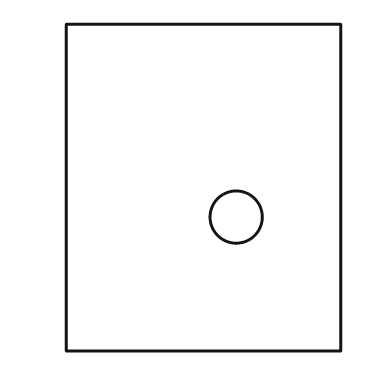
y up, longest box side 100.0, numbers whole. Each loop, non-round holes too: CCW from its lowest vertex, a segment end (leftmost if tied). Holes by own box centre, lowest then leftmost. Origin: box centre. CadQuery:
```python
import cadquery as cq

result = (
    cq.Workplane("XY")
    .moveTo(-42.0, -50.0)
    .lineTo(42.0, -50.0)
    .lineTo(42.0, 50.0)
    .lineTo(-42.0, 50.0)
    .close()
    .moveTo(10.0, -9.0)
    .circle(8.0)
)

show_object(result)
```